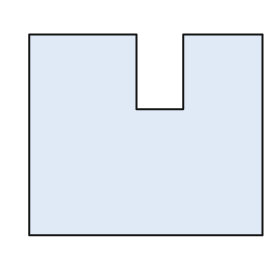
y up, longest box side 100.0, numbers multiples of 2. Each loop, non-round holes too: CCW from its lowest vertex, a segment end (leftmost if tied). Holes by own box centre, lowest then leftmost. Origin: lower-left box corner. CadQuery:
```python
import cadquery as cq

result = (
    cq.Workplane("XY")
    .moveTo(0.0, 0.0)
    .lineTo(100.0, 0.0)
    .lineTo(100.0, 86.0)
    .lineTo(66.0, 86.0)
    .lineTo(66.0, 54.0)
    .lineTo(46.0, 54.0)
    .lineTo(46.0, 86.0)
    .lineTo(0.0, 86.0)
    .close()
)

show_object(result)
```